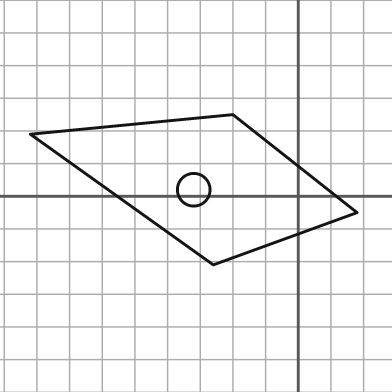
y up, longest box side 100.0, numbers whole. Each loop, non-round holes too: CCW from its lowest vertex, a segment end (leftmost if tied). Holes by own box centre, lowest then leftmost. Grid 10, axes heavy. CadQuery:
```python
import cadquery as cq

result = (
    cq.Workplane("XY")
    .moveTo(-26.0, -21.0)
    .lineTo(18.0, -5.0)
    .lineTo(-20.0, 25.0)
    .lineTo(-82.0, 19.0)
    .close()
    .moveTo(-32.0, 2.0)
    .circle(5.0)
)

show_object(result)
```